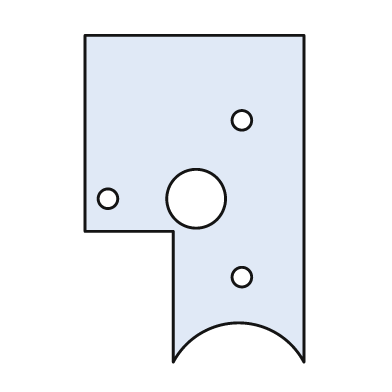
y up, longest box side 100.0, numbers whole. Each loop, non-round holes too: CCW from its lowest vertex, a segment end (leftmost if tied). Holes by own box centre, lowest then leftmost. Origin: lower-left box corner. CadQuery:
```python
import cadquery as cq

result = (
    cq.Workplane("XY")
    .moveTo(27.0, 0.0)
    .threePointArc((47.0, 12.0), (67.0, 0.0))
    .lineTo(67.0, 100.0)
    .lineTo(0.0, 100.0)
    .lineTo(0.0, 40.0)
    .lineTo(27.0, 40.0)
    .close()
    .moveTo(48.0, 26.0)
    .circle(3.0)
    .moveTo(7.0, 50.0)
    .circle(3.0)
    .moveTo(34.0, 50.0)
    .circle(9.0)
    .moveTo(48.0, 74.0)
    .circle(3.0)
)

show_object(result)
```